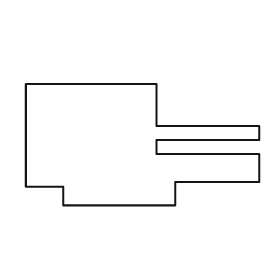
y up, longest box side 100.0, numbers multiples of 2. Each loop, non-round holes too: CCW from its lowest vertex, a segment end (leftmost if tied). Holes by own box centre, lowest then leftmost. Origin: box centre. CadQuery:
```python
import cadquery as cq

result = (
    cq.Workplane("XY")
    .moveTo(-34.0, -26.0)
    .lineTo(14.0, -26.0)
    .lineTo(14.0, -16.0)
    .lineTo(50.0, -16.0)
    .lineTo(50.0, -4.0)
    .lineTo(6.0, -4.0)
    .lineTo(6.0, 2.0)
    .lineTo(50.0, 2.0)
    .lineTo(50.0, 8.0)
    .lineTo(6.0, 8.0)
    .lineTo(6.0, 26.0)
    .lineTo(-50.0, 26.0)
    .lineTo(-50.0, -18.0)
    .lineTo(-34.0, -18.0)
    .close()
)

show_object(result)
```